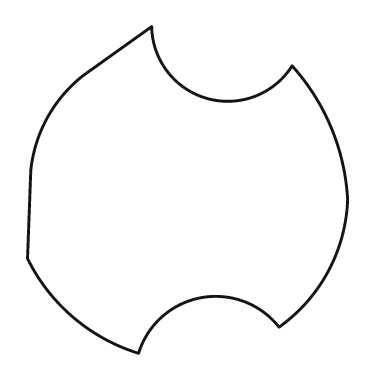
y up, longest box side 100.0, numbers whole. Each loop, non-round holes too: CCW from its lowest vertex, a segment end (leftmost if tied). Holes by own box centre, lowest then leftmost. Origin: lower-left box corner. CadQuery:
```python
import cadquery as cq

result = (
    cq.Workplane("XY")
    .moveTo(34.0, 0.0)
    .threePointArc((53.0, 17.0), (77.0, 8.0))
    .threePointArc((92.0, 25.0), (98.0, 47.0))
    .threePointArc((93.0, 69.0), (81.0, 88.0))
    .threePointArc((55.0, 78.0), (38.0, 100.0))
    .lineTo(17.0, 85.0)
    .threePointArc((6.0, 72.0), (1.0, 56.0))
    .lineTo(0.0, 29.0)
    .threePointArc((14.0, 11.0), (34.0, 0.0))
    .close()
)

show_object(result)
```